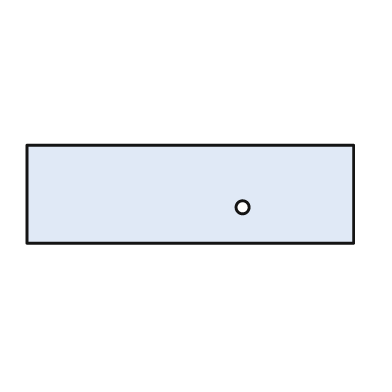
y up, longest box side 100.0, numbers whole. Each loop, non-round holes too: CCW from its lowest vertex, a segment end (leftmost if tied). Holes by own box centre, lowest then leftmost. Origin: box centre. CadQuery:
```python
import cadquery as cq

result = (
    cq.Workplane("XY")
    .moveTo(-50.0, -15.0)
    .lineTo(50.0, -15.0)
    .lineTo(50.0, 15.0)
    .lineTo(-50.0, 15.0)
    .close()
    .moveTo(16.0, -4.0)
    .circle(2.0)
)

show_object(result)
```